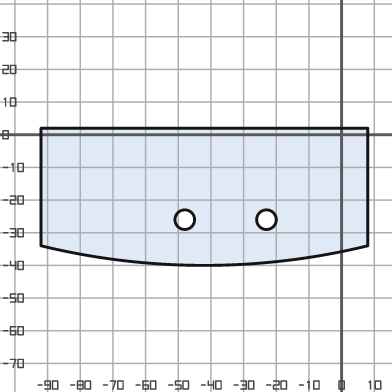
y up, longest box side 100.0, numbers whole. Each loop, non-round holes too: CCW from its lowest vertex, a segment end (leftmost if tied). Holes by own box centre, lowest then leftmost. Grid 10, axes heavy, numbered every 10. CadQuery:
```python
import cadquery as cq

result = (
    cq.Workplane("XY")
    .moveTo(-92.0, -34.0)
    .threePointArc((-42.0, -40.0), (8.0, -34.0))
    .lineTo(8.0, 2.0)
    .lineTo(-92.0, 2.0)
    .close()
    .moveTo(-48.0, -26.0)
    .circle(3.0)
    .moveTo(-23.0, -26.0)
    .circle(3.0)
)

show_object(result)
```